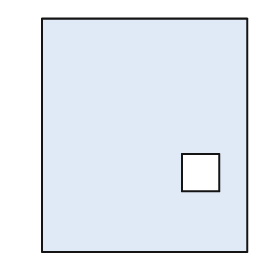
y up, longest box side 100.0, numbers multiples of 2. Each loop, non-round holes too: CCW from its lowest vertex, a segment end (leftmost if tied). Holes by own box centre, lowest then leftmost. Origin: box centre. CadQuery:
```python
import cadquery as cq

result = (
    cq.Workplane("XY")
    .moveTo(-44.0, -50.0)
    .lineTo(44.0, -50.0)
    .lineTo(44.0, 50.0)
    .lineTo(-44.0, 50.0)
    .close()
    .moveTo(16.0, -24.0)
    .lineTo(32.0, -24.0)
    .lineTo(32.0, -8.0)
    .lineTo(16.0, -8.0)
    .close()
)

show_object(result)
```